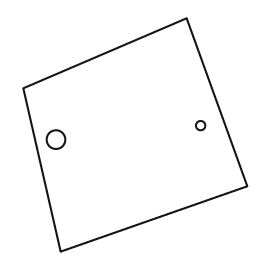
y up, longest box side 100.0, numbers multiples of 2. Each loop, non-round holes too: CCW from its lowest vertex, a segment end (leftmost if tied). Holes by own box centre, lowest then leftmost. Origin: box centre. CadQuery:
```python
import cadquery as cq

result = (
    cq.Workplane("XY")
    .moveTo(-32.0, -50.0)
    .lineTo(48.0, -22.0)
    .lineTo(22.0, 50.0)
    .lineTo(-48.0, 20.0)
    .close()
    .moveTo(-34.0, -2.0)
    .circle(4.0)
    .moveTo(28.0, 4.0)
    .circle(2.0)
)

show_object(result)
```